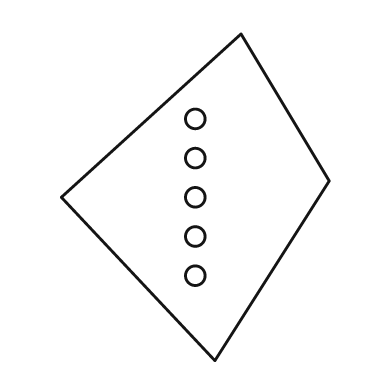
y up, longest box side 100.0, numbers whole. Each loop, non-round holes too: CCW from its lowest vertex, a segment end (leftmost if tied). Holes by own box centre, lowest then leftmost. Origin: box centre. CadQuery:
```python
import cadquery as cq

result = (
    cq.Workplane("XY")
    .moveTo(6.0, -50.0)
    .lineTo(41.0, 5.0)
    .lineTo(14.0, 50.0)
    .lineTo(-41.0, 0.0)
    .close()
    .moveTo(0.0, -24.0)
    .circle(3.0)
    .moveTo(0.0, -12.0)
    .circle(3.0)
    .moveTo(0.0, 0.0)
    .circle(3.0)
    .moveTo(0.0, 12.0)
    .circle(3.0)
    .moveTo(0.0, 24.0)
    .circle(3.0)
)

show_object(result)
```